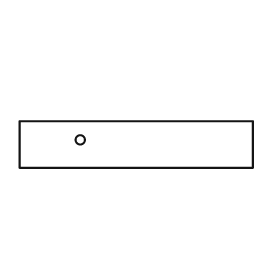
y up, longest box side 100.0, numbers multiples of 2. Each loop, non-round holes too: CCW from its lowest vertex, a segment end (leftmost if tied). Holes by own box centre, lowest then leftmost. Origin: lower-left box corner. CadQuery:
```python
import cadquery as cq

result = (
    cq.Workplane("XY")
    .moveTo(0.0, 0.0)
    .lineTo(100.0, 0.0)
    .lineTo(100.0, 20.0)
    .lineTo(0.0, 20.0)
    .close()
    .moveTo(26.0, 12.0)
    .circle(2.0)
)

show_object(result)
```